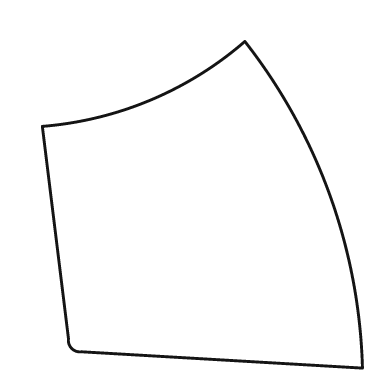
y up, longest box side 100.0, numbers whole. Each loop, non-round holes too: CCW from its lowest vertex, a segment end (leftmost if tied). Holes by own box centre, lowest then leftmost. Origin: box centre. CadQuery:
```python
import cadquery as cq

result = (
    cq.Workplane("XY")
    .moveTo(49.0, -50.0)
    .threePointArc((39.0, 3.0), (13.0, 50.0))
    .threePointArc((-16.0, 32.0), (-49.0, 24.0))
    .lineTo(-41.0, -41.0)
    .threePointArc((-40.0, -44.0), (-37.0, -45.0))
    .close()
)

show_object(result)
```